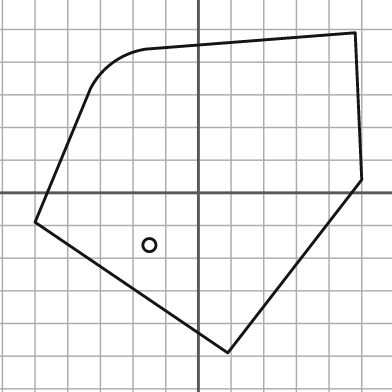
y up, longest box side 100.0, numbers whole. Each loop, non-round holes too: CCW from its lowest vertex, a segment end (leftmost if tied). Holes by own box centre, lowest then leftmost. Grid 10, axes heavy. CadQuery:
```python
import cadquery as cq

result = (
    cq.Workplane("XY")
    .moveTo(9.0, -49.0)
    .lineTo(50.0, 4.0)
    .lineTo(48.0, 49.0)
    .lineTo(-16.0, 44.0)
    .threePointArc((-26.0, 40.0), (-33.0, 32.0))
    .lineTo(-50.0, -9.0)
    .close()
    .moveTo(-15.0, -16.0)
    .circle(2.0)
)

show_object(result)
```